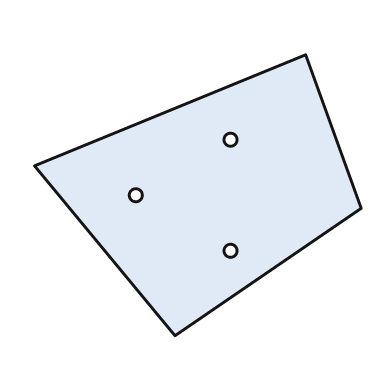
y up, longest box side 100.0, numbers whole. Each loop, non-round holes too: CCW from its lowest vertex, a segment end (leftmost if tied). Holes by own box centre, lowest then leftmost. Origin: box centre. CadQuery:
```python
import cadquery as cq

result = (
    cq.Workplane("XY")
    .moveTo(-7.0, -43.0)
    .lineTo(50.0, -4.0)
    .lineTo(33.0, 43.0)
    .lineTo(-50.0, 9.0)
    .close()
    .moveTo(10.0, -17.0)
    .circle(2.0)
    .moveTo(-19.0, 0.0)
    .circle(2.0)
    .moveTo(10.0, 17.0)
    .circle(2.0)
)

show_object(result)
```